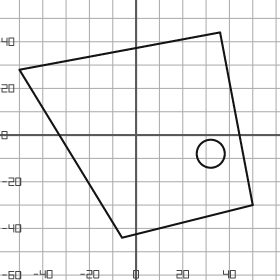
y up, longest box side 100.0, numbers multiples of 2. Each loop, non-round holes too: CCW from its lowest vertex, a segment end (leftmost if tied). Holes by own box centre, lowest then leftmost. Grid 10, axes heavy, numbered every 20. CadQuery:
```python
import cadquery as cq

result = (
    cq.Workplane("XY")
    .moveTo(-6.0, -44.0)
    .lineTo(50.0, -30.0)
    .lineTo(36.0, 44.0)
    .lineTo(-50.0, 28.0)
    .close()
    .moveTo(32.0, -8.0)
    .circle(6.0)
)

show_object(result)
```